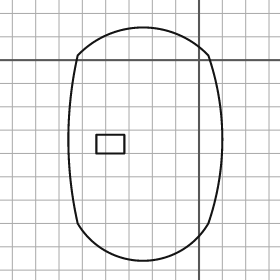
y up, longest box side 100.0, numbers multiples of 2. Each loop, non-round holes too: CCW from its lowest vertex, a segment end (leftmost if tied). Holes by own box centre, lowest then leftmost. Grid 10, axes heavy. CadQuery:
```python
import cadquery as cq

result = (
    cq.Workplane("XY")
    .moveTo(-52.0, -70.0)
    .threePointArc((-24.0, -86.0), (4.0, -70.0))
    .threePointArc((10.0, -34.0), (4.0, 2.0))
    .threePointArc((-24.0, 14.0), (-52.0, 2.0))
    .threePointArc((-56.0, -34.0), (-52.0, -70.0))
    .close()
    .moveTo(-44.0, -40.0)
    .lineTo(-32.0, -40.0)
    .lineTo(-32.0, -32.0)
    .lineTo(-44.0, -32.0)
    .close()
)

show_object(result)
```